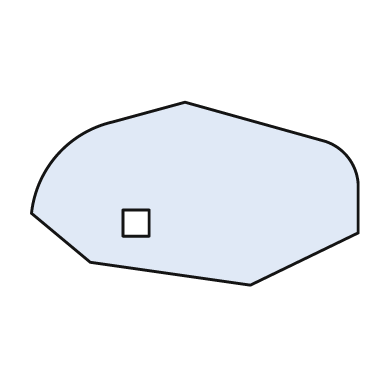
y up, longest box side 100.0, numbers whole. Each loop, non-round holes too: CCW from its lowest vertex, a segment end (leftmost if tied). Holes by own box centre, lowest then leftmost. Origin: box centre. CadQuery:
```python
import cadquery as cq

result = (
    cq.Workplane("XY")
    .moveTo(17.0, -28.0)
    .lineTo(50.0, -12.0)
    .lineTo(50.0, 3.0)
    .threePointArc((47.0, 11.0), (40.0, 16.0))
    .lineTo(-3.0, 28.0)
    .lineTo(-25.0, 22.0)
    .threePointArc((-42.0, 12.0), (-50.0, -6.0))
    .lineTo(-32.0, -21.0)
    .close()
    .moveTo(-22.0, -13.0)
    .lineTo(-14.0, -13.0)
    .lineTo(-14.0, -5.0)
    .lineTo(-22.0, -5.0)
    .close()
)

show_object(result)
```